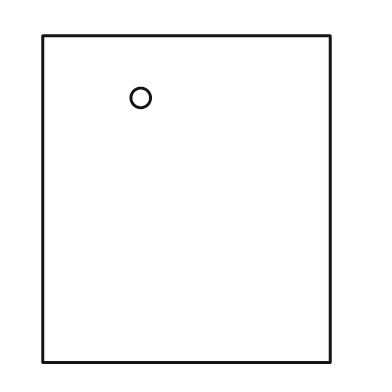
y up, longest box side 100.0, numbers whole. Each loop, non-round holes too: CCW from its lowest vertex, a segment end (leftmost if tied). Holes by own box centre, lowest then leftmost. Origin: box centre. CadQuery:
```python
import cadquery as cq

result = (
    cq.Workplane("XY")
    .moveTo(-44.0, -50.0)
    .lineTo(44.0, -50.0)
    .lineTo(44.0, 50.0)
    .lineTo(-44.0, 50.0)
    .close()
    .moveTo(-14.0, 31.0)
    .circle(3.0)
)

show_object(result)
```